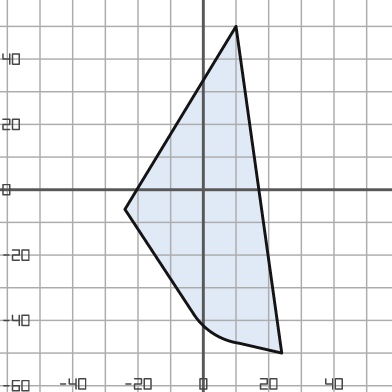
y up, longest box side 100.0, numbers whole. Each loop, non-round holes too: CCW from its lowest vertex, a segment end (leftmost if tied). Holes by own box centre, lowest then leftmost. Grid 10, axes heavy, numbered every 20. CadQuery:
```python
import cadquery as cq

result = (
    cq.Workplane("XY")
    .moveTo(24.0, -50.0)
    .lineTo(10.0, 50.0)
    .lineTo(-24.0, -6.0)
    .lineTo(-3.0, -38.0)
    .threePointArc((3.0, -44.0), (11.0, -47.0))
    .close()
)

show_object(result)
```